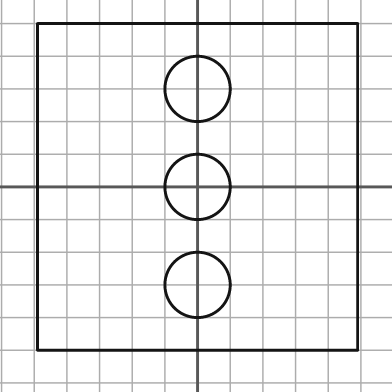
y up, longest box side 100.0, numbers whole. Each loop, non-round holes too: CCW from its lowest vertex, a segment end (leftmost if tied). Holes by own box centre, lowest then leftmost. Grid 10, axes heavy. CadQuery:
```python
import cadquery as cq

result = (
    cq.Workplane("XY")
    .moveTo(-49.0, -50.0)
    .lineTo(49.0, -50.0)
    .lineTo(49.0, 50.0)
    .lineTo(-49.0, 50.0)
    .close()
    .moveTo(0.0, -30.0)
    .circle(10.0)
    .moveTo(0.0, 0.0)
    .circle(10.0)
    .moveTo(0.0, 30.0)
    .circle(10.0)
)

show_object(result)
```